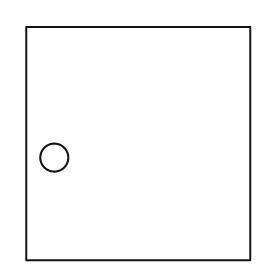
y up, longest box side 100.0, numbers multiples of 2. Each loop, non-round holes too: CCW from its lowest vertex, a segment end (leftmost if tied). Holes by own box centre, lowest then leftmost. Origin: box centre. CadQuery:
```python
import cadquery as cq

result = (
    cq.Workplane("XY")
    .moveTo(-48.0, -50.0)
    .lineTo(48.0, -50.0)
    .lineTo(48.0, 50.0)
    .lineTo(-48.0, 50.0)
    .close()
    .moveTo(-36.0, -6.0)
    .circle(6.0)
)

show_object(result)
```